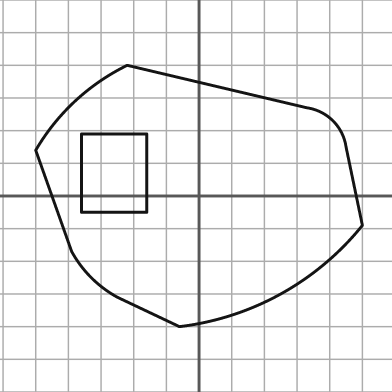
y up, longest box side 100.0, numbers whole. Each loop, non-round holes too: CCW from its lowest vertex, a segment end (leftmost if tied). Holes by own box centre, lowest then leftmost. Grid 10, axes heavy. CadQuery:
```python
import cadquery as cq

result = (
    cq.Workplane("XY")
    .moveTo(-6.0, -40.0)
    .threePointArc((25.0, -30.0), (50.0, -9.0))
    .lineTo(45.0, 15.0)
    .threePointArc((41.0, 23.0), (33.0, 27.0))
    .lineTo(-22.0, 40.0)
    .threePointArc((-38.0, 29.0), (-50.0, 14.0))
    .lineTo(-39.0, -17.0)
    .threePointArc((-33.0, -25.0), (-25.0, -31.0))
    .close()
    .moveTo(-36.0, -5.0)
    .lineTo(-16.0, -5.0)
    .lineTo(-16.0, 19.0)
    .lineTo(-36.0, 19.0)
    .close()
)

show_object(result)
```